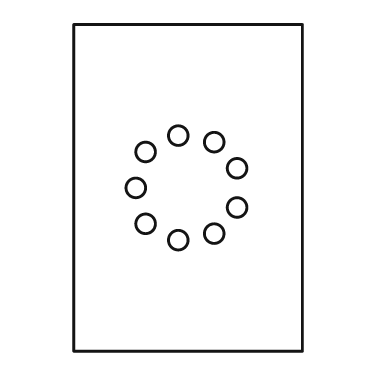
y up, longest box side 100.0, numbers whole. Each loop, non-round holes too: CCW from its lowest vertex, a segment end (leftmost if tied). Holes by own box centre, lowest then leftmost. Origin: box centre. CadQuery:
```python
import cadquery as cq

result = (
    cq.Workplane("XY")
    .moveTo(-35.0, -50.0)
    .lineTo(35.0, -50.0)
    .lineTo(35.0, 50.0)
    .lineTo(-35.0, 50.0)
    .close()
    .moveTo(-3.0, -16.0)
    .circle(3.0)
    .moveTo(8.0, -14.0)
    .circle(3.0)
    .moveTo(-13.0, -11.0)
    .circle(3.0)
    .moveTo(15.0, -6.0)
    .circle(3.0)
    .moveTo(-16.0, 0.0)
    .circle(3.0)
    .moveTo(15.0, 6.0)
    .circle(3.0)
    .moveTo(-13.0, 11.0)
    .circle(3.0)
    .moveTo(8.0, 14.0)
    .circle(3.0)
    .moveTo(-3.0, 16.0)
    .circle(3.0)
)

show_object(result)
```